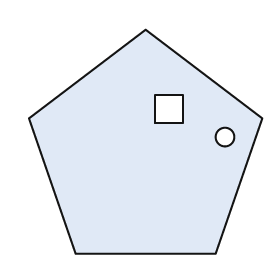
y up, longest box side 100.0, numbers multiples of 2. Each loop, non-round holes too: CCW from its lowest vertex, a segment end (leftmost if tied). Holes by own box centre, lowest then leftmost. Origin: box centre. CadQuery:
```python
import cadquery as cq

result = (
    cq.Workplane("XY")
    .moveTo(-30.0, -48.0)
    .lineTo(30.0, -48.0)
    .lineTo(50.0, 10.0)
    .lineTo(0.0, 48.0)
    .lineTo(-50.0, 10.0)
    .close()
    .moveTo(34.0, 2.0)
    .circle(4.0)
    .moveTo(4.0, 8.0)
    .lineTo(16.0, 8.0)
    .lineTo(16.0, 20.0)
    .lineTo(4.0, 20.0)
    .close()
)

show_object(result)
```